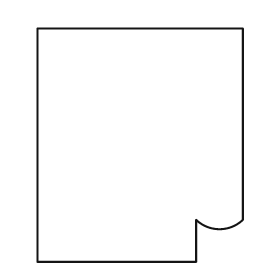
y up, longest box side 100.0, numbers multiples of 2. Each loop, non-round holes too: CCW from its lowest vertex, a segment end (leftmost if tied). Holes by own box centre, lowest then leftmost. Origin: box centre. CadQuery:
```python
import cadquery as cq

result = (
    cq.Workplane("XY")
    .moveTo(-44.0, -50.0)
    .lineTo(24.0, -50.0)
    .lineTo(24.0, -32.0)
    .threePointArc((34.0, -36.0), (44.0, -32.0))
    .lineTo(44.0, 50.0)
    .lineTo(-44.0, 50.0)
    .close()
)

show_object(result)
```